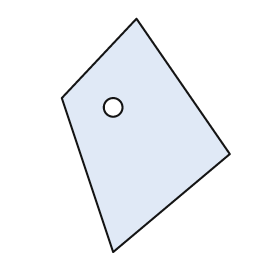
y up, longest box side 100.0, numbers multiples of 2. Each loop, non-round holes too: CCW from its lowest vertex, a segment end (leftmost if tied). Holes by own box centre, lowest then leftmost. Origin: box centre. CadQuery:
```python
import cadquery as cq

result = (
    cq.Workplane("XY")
    .moveTo(-14.0, -50.0)
    .lineTo(36.0, -8.0)
    .lineTo(-4.0, 50.0)
    .lineTo(-36.0, 16.0)
    .close()
    .moveTo(-14.0, 12.0)
    .circle(4.0)
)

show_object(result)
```